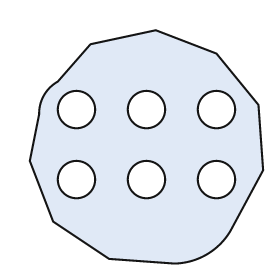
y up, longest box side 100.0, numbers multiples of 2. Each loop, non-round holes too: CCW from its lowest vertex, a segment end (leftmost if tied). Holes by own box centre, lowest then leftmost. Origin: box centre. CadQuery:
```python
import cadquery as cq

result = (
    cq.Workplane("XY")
    .moveTo(12.0, -50.0)
    .threePointArc((26.0, -46.0), (36.0, -36.0))
    .lineTo(50.0, -10.0)
    .lineTo(48.0, 18.0)
    .lineTo(30.0, 40.0)
    .lineTo(4.0, 50.0)
    .lineTo(-24.0, 44.0)
    .lineTo(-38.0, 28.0)
    .threePointArc((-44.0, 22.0), (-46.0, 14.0))
    .lineTo(-50.0, -6.0)
    .lineTo(-40.0, -32.0)
    .lineTo(-16.0, -48.0)
    .close()
    .moveTo(-30.0, -14.0)
    .circle(8.0)
    .moveTo(0.0, -14.0)
    .circle(8.0)
    .moveTo(30.0, -14.0)
    .circle(8.0)
    .moveTo(-30.0, 16.0)
    .circle(8.0)
    .moveTo(0.0, 16.0)
    .circle(8.0)
    .moveTo(30.0, 16.0)
    .circle(8.0)
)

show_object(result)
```